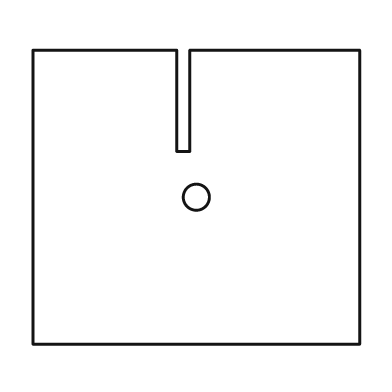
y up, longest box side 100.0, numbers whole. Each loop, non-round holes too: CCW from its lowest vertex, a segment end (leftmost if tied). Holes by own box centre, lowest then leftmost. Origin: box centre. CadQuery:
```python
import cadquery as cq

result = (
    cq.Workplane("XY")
    .moveTo(-50.0, -45.0)
    .lineTo(50.0, -45.0)
    .lineTo(50.0, 45.0)
    .lineTo(-2.0, 45.0)
    .lineTo(-2.0, 14.0)
    .lineTo(-6.0, 14.0)
    .lineTo(-6.0, 45.0)
    .lineTo(-50.0, 45.0)
    .close()
    .moveTo(0.0, 0.0)
    .circle(4.0)
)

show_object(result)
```